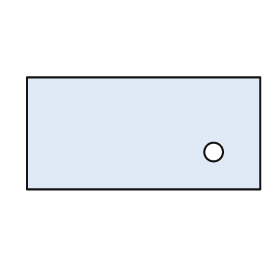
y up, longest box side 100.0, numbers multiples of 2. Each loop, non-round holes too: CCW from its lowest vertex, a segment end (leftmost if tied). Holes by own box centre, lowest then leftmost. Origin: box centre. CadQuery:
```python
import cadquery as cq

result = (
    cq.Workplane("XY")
    .moveTo(-50.0, -24.0)
    .lineTo(50.0, -24.0)
    .lineTo(50.0, 24.0)
    .lineTo(-50.0, 24.0)
    .close()
    .moveTo(30.0, -8.0)
    .circle(4.0)
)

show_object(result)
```